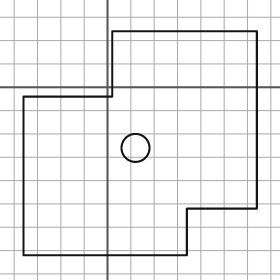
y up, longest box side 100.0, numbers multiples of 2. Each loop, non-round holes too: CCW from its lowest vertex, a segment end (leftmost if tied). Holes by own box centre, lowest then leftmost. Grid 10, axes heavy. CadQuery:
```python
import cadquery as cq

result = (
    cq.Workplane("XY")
    .moveTo(-36.0, -72.0)
    .lineTo(34.0, -72.0)
    .lineTo(34.0, -52.0)
    .lineTo(64.0, -52.0)
    .lineTo(64.0, 24.0)
    .lineTo(2.0, 24.0)
    .lineTo(2.0, -4.0)
    .lineTo(-36.0, -4.0)
    .close()
    .moveTo(12.0, -26.0)
    .circle(6.0)
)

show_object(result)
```